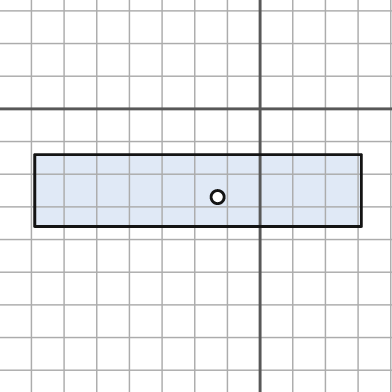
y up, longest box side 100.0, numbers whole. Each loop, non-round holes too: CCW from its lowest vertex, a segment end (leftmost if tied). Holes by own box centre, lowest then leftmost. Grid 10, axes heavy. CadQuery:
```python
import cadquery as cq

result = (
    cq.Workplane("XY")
    .moveTo(-69.0, -36.0)
    .lineTo(31.0, -36.0)
    .lineTo(31.0, -14.0)
    .lineTo(-69.0, -14.0)
    .close()
    .moveTo(-13.0, -27.0)
    .circle(2.0)
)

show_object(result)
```